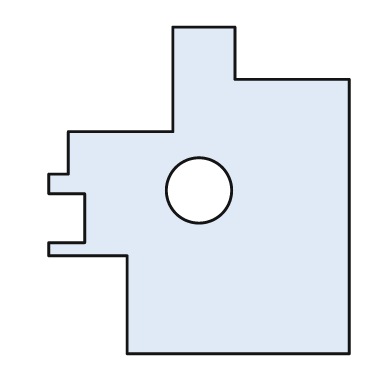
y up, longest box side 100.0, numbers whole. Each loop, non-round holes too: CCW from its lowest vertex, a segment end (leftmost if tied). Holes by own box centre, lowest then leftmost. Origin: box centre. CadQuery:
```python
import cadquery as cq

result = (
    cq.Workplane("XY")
    .moveTo(-22.0, -50.0)
    .lineTo(46.0, -50.0)
    .lineTo(46.0, 34.0)
    .lineTo(11.0, 34.0)
    .lineTo(11.0, 50.0)
    .lineTo(-8.0, 50.0)
    .lineTo(-8.0, 18.0)
    .lineTo(-40.0, 18.0)
    .lineTo(-40.0, 5.0)
    .lineTo(-46.0, 5.0)
    .lineTo(-46.0, -1.0)
    .lineTo(-35.0, -1.0)
    .lineTo(-35.0, -16.0)
    .lineTo(-46.0, -16.0)
    .lineTo(-46.0, -20.0)
    .lineTo(-22.0, -20.0)
    .close()
    .moveTo(0.0, 0.0)
    .circle(10.0)
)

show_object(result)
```